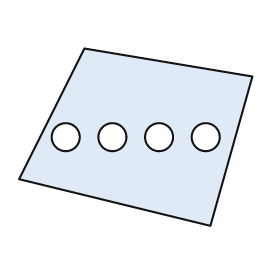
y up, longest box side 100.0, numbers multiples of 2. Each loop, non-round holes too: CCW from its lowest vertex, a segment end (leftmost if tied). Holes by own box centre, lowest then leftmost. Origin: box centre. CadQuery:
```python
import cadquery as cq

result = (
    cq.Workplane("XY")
    .moveTo(32.0, -38.0)
    .lineTo(50.0, 26.0)
    .lineTo(-22.0, 38.0)
    .lineTo(-50.0, -18.0)
    .close()
    .moveTo(-30.0, 0.0)
    .circle(6.0)
    .moveTo(-10.0, 0.0)
    .circle(6.0)
    .moveTo(10.0, 0.0)
    .circle(6.0)
    .moveTo(30.0, 0.0)
    .circle(6.0)
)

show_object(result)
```